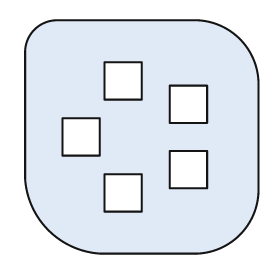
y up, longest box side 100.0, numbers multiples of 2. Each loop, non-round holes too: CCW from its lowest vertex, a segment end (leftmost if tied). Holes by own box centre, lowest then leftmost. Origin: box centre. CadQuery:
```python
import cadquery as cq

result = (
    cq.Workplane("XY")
    .moveTo(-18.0, -50.0)
    .lineTo(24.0, -50.0)
    .threePointArc((42.0, -42.0), (50.0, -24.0))
    .lineTo(50.0, 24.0)
    .threePointArc((42.0, 42.0), (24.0, 50.0))
    .lineTo(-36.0, 50.0)
    .threePointArc((-46.0, 46.0), (-50.0, 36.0))
    .lineTo(-50.0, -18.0)
    .threePointArc((-40.0, -40.0), (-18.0, -50.0))
    .close()
    .moveTo(-16.0, -32.0)
    .lineTo(0.0, -32.0)
    .lineTo(0.0, -16.0)
    .lineTo(-16.0, -16.0)
    .close()
    .moveTo(12.0, -22.0)
    .lineTo(28.0, -22.0)
    .lineTo(28.0, -6.0)
    .lineTo(12.0, -6.0)
    .close()
    .moveTo(-34.0, -8.0)
    .lineTo(-18.0, -8.0)
    .lineTo(-18.0, 8.0)
    .lineTo(-34.0, 8.0)
    .close()
    .moveTo(12.0, 6.0)
    .lineTo(28.0, 6.0)
    .lineTo(28.0, 22.0)
    .lineTo(12.0, 22.0)
    .close()
    .moveTo(-16.0, 16.0)
    .lineTo(0.0, 16.0)
    .lineTo(0.0, 32.0)
    .lineTo(-16.0, 32.0)
    .close()
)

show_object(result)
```